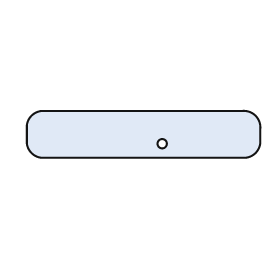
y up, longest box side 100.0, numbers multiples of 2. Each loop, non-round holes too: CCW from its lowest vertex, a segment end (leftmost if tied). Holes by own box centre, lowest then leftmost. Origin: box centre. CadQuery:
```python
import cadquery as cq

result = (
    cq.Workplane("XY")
    .moveTo(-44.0, -10.0)
    .lineTo(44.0, -10.0)
    .threePointArc((48.0, -8.0), (50.0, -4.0))
    .lineTo(50.0, 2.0)
    .threePointArc((48.0, 8.0), (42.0, 10.0))
    .lineTo(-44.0, 10.0)
    .threePointArc((-48.0, 8.0), (-50.0, 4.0))
    .lineTo(-50.0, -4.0)
    .threePointArc((-48.0, -8.0), (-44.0, -10.0))
    .close()
    .moveTo(8.0, -4.0)
    .circle(2.0)
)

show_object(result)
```